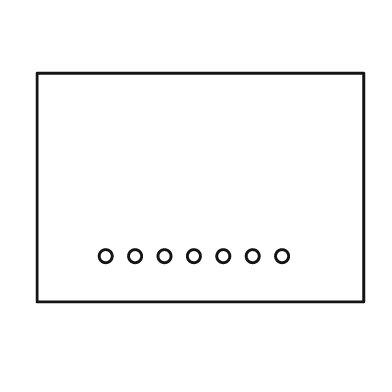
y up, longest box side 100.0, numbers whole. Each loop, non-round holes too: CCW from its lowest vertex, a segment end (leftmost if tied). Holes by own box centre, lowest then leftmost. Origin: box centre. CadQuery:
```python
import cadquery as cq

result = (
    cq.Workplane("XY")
    .moveTo(-50.0, -35.0)
    .lineTo(50.0, -35.0)
    .lineTo(50.0, 35.0)
    .lineTo(-50.0, 35.0)
    .close()
    .moveTo(-29.0, -21.0)
    .circle(2.0)
    .moveTo(-20.0, -21.0)
    .circle(2.0)
    .moveTo(-11.0, -21.0)
    .circle(2.0)
    .moveTo(-2.0, -21.0)
    .circle(2.0)
    .moveTo(7.0, -21.0)
    .circle(2.0)
    .moveTo(16.0, -21.0)
    .circle(2.0)
    .moveTo(25.0, -21.0)
    .circle(2.0)
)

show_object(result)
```